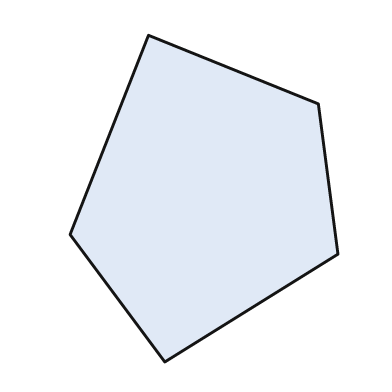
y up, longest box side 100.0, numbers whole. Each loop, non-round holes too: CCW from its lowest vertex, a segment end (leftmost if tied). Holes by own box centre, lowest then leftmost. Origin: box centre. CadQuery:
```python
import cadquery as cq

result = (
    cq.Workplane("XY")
    .moveTo(-12.0, -50.0)
    .lineTo(41.0, -17.0)
    .lineTo(35.0, 29.0)
    .lineTo(-17.0, 50.0)
    .lineTo(-41.0, -11.0)
    .close()
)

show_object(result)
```